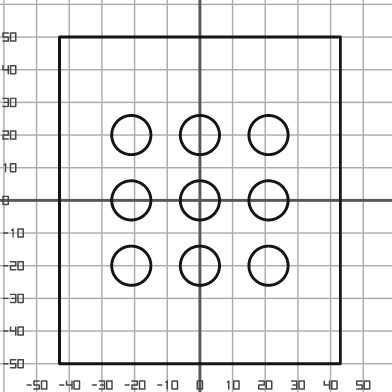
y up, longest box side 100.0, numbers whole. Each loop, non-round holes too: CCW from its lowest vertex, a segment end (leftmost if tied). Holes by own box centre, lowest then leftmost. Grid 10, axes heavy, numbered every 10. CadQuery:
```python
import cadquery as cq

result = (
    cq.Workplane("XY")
    .moveTo(-43.0, -50.0)
    .lineTo(43.0, -50.0)
    .lineTo(43.0, 50.0)
    .lineTo(-43.0, 50.0)
    .close()
    .moveTo(-21.0, -20.0)
    .circle(6.0)
    .moveTo(0.0, -20.0)
    .circle(6.0)
    .moveTo(21.0, -20.0)
    .circle(6.0)
    .moveTo(-21.0, 0.0)
    .circle(6.0)
    .moveTo(0.0, 0.0)
    .circle(6.0)
    .moveTo(21.0, 0.0)
    .circle(6.0)
    .moveTo(-21.0, 20.0)
    .circle(6.0)
    .moveTo(0.0, 20.0)
    .circle(6.0)
    .moveTo(21.0, 20.0)
    .circle(6.0)
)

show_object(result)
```